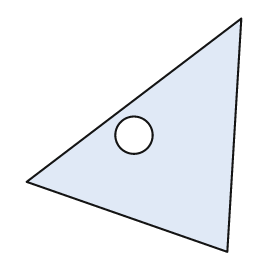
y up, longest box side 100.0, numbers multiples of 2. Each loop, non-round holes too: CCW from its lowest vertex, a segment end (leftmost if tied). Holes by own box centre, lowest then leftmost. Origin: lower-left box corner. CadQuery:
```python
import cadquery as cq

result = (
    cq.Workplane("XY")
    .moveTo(86.0, 0.0)
    .lineTo(92.0, 100.0)
    .lineTo(0.0, 30.0)
    .close()
    .moveTo(46.0, 50.0)
    .circle(8.0)
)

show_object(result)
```